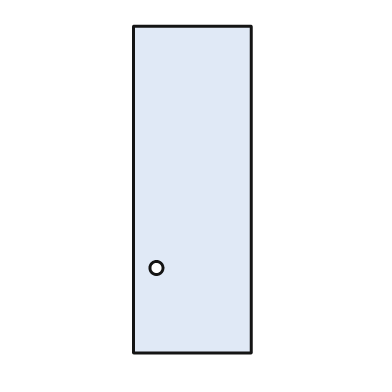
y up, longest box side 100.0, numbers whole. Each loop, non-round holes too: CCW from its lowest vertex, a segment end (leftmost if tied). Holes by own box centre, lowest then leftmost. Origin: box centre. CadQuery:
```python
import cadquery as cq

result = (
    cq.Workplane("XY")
    .moveTo(-18.0, -50.0)
    .lineTo(18.0, -50.0)
    .lineTo(18.0, 50.0)
    .lineTo(-18.0, 50.0)
    .close()
    .moveTo(-11.0, -24.0)
    .circle(2.0)
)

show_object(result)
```